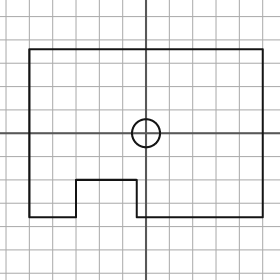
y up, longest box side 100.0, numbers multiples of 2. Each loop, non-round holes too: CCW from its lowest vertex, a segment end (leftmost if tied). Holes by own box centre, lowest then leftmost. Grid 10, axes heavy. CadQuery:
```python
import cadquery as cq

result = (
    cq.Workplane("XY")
    .moveTo(-50.0, -36.0)
    .lineTo(-30.0, -36.0)
    .lineTo(-30.0, -20.0)
    .lineTo(-4.0, -20.0)
    .lineTo(-4.0, -36.0)
    .lineTo(50.0, -36.0)
    .lineTo(50.0, 36.0)
    .lineTo(-50.0, 36.0)
    .close()
    .moveTo(0.0, 0.0)
    .circle(6.0)
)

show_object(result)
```